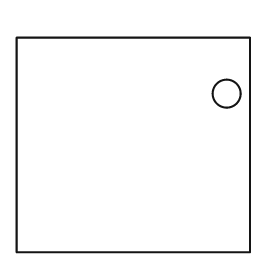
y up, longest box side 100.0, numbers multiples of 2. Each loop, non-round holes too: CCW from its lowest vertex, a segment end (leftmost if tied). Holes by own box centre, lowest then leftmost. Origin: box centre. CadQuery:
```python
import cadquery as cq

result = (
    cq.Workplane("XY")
    .moveTo(-50.0, -46.0)
    .lineTo(50.0, -46.0)
    .lineTo(50.0, 46.0)
    .lineTo(-50.0, 46.0)
    .close()
    .moveTo(40.0, 22.0)
    .circle(6.0)
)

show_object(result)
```